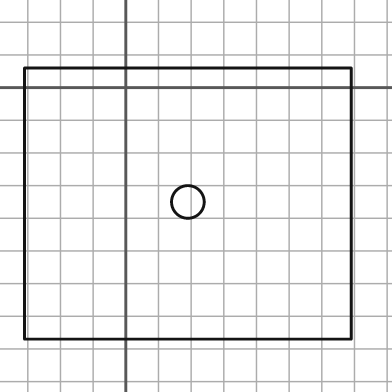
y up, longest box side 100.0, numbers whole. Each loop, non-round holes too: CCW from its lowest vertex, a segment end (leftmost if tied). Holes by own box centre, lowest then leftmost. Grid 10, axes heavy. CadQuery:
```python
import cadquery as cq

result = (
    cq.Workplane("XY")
    .moveTo(-31.0, -77.0)
    .lineTo(69.0, -77.0)
    .lineTo(69.0, 6.0)
    .lineTo(-31.0, 6.0)
    .close()
    .moveTo(19.0, -35.0)
    .circle(5.0)
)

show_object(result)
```